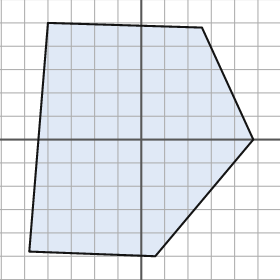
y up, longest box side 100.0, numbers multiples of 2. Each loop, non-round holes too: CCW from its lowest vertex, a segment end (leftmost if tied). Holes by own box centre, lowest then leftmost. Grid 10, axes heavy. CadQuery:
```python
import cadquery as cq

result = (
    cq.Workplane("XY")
    .moveTo(6.0, -50.0)
    .lineTo(48.0, 0.0)
    .lineTo(26.0, 48.0)
    .lineTo(-40.0, 50.0)
    .lineTo(-48.0, -48.0)
    .close()
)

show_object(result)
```